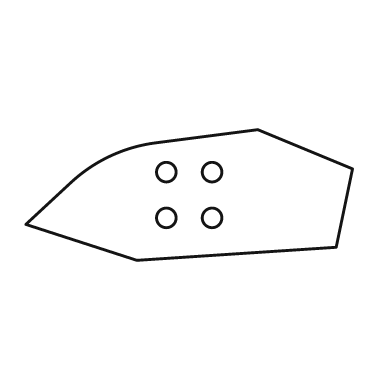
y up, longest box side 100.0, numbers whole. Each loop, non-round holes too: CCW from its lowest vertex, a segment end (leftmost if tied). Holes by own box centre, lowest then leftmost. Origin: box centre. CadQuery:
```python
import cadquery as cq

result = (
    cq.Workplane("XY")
    .moveTo(-16.0, -20.0)
    .lineTo(45.0, -16.0)
    .lineTo(50.0, 8.0)
    .lineTo(21.0, 20.0)
    .lineTo(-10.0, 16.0)
    .threePointArc((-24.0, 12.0), (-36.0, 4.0))
    .lineTo(-50.0, -9.0)
    .close()
    .moveTo(-7.0, -7.0)
    .circle(3.0)
    .moveTo(7.0, -7.0)
    .circle(3.0)
    .moveTo(-7.0, 7.0)
    .circle(3.0)
    .moveTo(7.0, 7.0)
    .circle(3.0)
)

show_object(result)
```